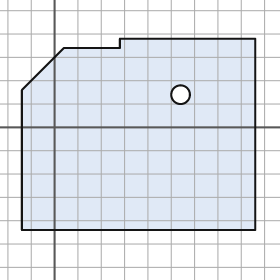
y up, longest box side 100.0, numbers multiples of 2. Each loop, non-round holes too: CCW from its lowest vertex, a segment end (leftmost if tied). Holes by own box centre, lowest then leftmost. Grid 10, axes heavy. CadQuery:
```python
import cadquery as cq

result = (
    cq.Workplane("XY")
    .moveTo(-14.0, -44.0)
    .lineTo(86.0, -44.0)
    .lineTo(86.0, 38.0)
    .lineTo(28.0, 38.0)
    .lineTo(28.0, 34.0)
    .lineTo(4.0, 34.0)
    .lineTo(-14.0, 16.0)
    .close()
    .moveTo(54.0, 14.0)
    .circle(4.0)
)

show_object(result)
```